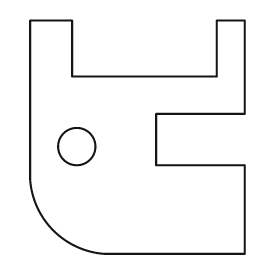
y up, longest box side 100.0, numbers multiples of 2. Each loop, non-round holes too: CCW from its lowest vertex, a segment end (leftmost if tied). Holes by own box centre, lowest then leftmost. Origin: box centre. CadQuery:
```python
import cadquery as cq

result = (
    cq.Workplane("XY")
    .moveTo(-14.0, -50.0)
    .lineTo(46.0, -50.0)
    .lineTo(46.0, -12.0)
    .lineTo(8.0, -12.0)
    .lineTo(8.0, 10.0)
    .lineTo(46.0, 10.0)
    .lineTo(46.0, 50.0)
    .lineTo(34.0, 50.0)
    .lineTo(34.0, 26.0)
    .lineTo(-28.0, 26.0)
    .lineTo(-28.0, 50.0)
    .lineTo(-46.0, 50.0)
    .lineTo(-46.0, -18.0)
    .threePointArc((-36.0, -40.0), (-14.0, -50.0))
    .close()
    .moveTo(-26.0, -4.0)
    .circle(8.0)
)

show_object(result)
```